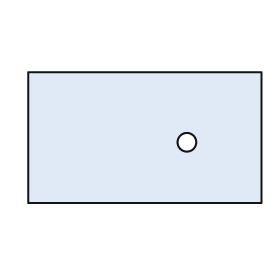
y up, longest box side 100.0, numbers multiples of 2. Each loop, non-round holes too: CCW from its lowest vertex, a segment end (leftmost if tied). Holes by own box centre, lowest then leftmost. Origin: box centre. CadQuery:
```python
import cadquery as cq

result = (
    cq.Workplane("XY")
    .moveTo(-50.0, -28.0)
    .lineTo(50.0, -28.0)
    .lineTo(50.0, 28.0)
    .lineTo(-50.0, 28.0)
    .close()
    .moveTo(18.0, -2.0)
    .circle(4.0)
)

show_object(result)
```